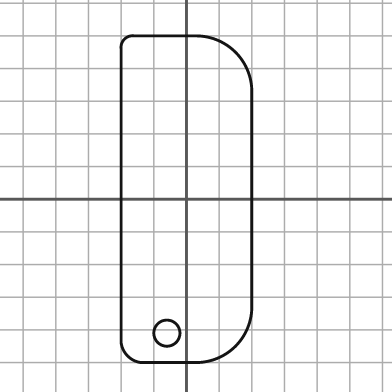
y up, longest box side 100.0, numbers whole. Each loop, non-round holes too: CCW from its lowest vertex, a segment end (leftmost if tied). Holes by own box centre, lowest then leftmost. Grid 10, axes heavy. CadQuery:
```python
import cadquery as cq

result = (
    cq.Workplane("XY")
    .moveTo(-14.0, -50.0)
    .lineTo(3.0, -50.0)
    .threePointArc((15.0, -45.0), (20.0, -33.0))
    .lineTo(20.0, 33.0)
    .threePointArc((15.0, 45.0), (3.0, 50.0))
    .lineTo(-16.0, 50.0)
    .threePointArc((-19.0, 49.0), (-20.0, 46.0))
    .lineTo(-20.0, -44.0)
    .threePointArc((-18.0, -48.0), (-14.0, -50.0))
    .close()
    .moveTo(-6.0, -41.0)
    .circle(4.0)
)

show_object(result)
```